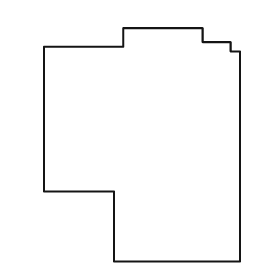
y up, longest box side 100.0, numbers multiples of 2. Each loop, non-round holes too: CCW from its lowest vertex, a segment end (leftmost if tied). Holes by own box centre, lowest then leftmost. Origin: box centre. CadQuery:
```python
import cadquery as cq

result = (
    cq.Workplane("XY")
    .moveTo(-12.0, -50.0)
    .lineTo(42.0, -50.0)
    .lineTo(42.0, 40.0)
    .lineTo(38.0, 40.0)
    .lineTo(38.0, 44.0)
    .lineTo(26.0, 44.0)
    .lineTo(26.0, 50.0)
    .lineTo(-8.0, 50.0)
    .lineTo(-8.0, 42.0)
    .lineTo(-42.0, 42.0)
    .lineTo(-42.0, -20.0)
    .lineTo(-12.0, -20.0)
    .close()
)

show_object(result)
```